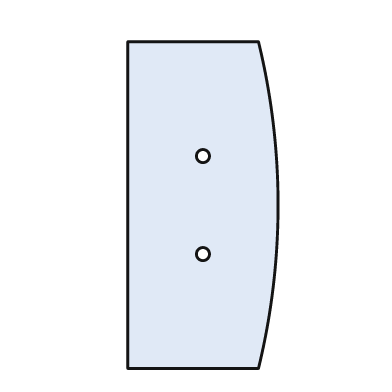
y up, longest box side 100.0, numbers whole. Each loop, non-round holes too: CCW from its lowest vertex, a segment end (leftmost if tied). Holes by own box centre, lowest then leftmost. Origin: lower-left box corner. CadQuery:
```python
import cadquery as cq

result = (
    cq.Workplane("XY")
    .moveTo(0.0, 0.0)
    .lineTo(40.0, 0.0)
    .threePointArc((46.0, 50.0), (40.0, 100.0))
    .lineTo(0.0, 100.0)
    .close()
    .moveTo(23.0, 35.0)
    .circle(2.0)
    .moveTo(23.0, 65.0)
    .circle(2.0)
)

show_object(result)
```